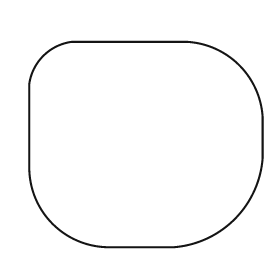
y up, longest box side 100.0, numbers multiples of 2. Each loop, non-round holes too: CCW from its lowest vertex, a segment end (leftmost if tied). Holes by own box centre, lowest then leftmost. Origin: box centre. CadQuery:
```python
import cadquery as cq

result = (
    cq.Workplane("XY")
    .moveTo(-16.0, -44.0)
    .lineTo(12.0, -44.0)
    .threePointArc((38.0, -32.0), (50.0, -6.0))
    .lineTo(50.0, 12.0)
    .threePointArc((40.0, 34.0), (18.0, 44.0))
    .lineTo(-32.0, 44.0)
    .threePointArc((-44.0, 38.0), (-50.0, 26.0))
    .lineTo(-50.0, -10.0)
    .threePointArc((-40.0, -34.0), (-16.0, -44.0))
    .close()
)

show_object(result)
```